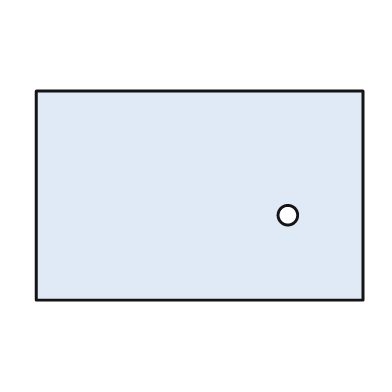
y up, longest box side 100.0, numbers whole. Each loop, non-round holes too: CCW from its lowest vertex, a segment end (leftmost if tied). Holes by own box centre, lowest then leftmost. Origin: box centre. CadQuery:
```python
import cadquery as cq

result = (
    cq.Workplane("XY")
    .moveTo(-50.0, -32.0)
    .lineTo(50.0, -32.0)
    .lineTo(50.0, 32.0)
    .lineTo(-50.0, 32.0)
    .close()
    .moveTo(27.0, -6.0)
    .circle(3.0)
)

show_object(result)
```